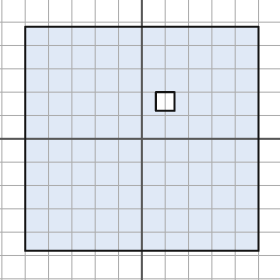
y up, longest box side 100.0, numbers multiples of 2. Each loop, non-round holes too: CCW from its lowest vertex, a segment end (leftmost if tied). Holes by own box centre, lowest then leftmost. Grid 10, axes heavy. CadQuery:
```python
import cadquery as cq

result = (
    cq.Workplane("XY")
    .moveTo(-50.0, -48.0)
    .lineTo(50.0, -48.0)
    .lineTo(50.0, 48.0)
    .lineTo(-50.0, 48.0)
    .close()
    .moveTo(6.0, 12.0)
    .lineTo(14.0, 12.0)
    .lineTo(14.0, 20.0)
    .lineTo(6.0, 20.0)
    .close()
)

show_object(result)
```